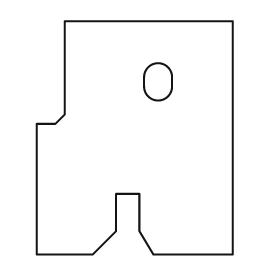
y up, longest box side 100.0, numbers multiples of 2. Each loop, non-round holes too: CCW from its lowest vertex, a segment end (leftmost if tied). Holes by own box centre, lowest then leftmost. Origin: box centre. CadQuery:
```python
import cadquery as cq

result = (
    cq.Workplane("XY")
    .moveTo(-42.0, -50.0)
    .lineTo(-18.0, -50.0)
    .lineTo(-8.0, -40.0)
    .lineTo(-8.0, -24.0)
    .lineTo(2.0, -24.0)
    .lineTo(2.0, -40.0)
    .lineTo(8.0, -50.0)
    .lineTo(42.0, -50.0)
    .lineTo(42.0, 50.0)
    .lineTo(-30.0, 50.0)
    .lineTo(-30.0, 10.0)
    .lineTo(-34.0, 6.0)
    .lineTo(-42.0, 6.0)
    .close()
    .moveTo(4.0, 22.0)
    .threePointArc((10.0, 16.0), (16.0, 22.0))
    .lineTo(16.0, 26.0)
    .threePointArc((10.0, 32.0), (4.0, 26.0))
    .close()
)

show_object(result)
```